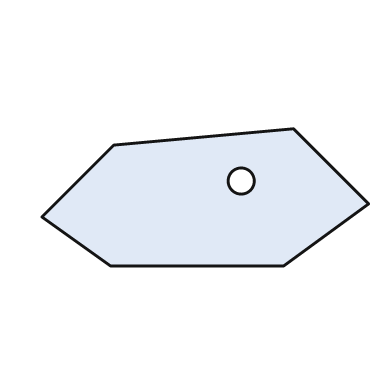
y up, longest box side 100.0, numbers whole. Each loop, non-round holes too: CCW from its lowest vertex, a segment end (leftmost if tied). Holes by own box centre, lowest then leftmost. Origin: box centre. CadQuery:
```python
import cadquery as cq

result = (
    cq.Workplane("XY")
    .moveTo(-29.0, -21.0)
    .lineTo(24.0, -21.0)
    .lineTo(50.0, -2.0)
    .lineTo(27.0, 21.0)
    .lineTo(-28.0, 16.0)
    .lineTo(-50.0, -6.0)
    .close()
    .moveTo(11.0, 5.0)
    .circle(4.0)
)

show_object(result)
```